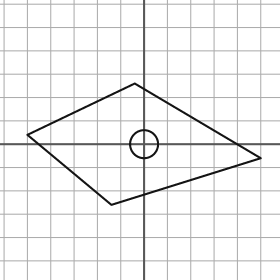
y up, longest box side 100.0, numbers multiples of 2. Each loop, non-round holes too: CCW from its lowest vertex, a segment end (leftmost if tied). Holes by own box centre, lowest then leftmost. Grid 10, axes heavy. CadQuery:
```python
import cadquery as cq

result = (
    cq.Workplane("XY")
    .moveTo(-14.0, -26.0)
    .lineTo(50.0, -6.0)
    .lineTo(-4.0, 26.0)
    .lineTo(-50.0, 4.0)
    .close()
    .moveTo(0.0, 0.0)
    .circle(6.0)
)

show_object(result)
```